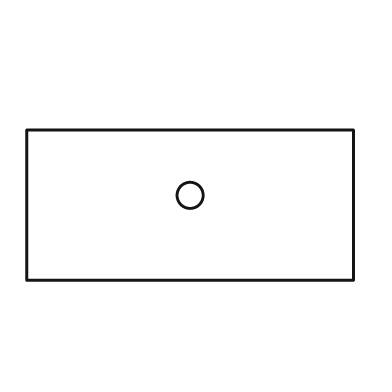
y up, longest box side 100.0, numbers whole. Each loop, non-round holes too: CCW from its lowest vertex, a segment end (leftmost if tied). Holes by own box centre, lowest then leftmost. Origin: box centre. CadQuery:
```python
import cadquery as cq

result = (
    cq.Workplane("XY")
    .moveTo(-50.0, -23.0)
    .lineTo(50.0, -23.0)
    .lineTo(50.0, 23.0)
    .lineTo(-50.0, 23.0)
    .close()
    .moveTo(0.0, 3.0)
    .circle(4.0)
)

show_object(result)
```